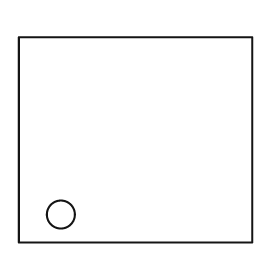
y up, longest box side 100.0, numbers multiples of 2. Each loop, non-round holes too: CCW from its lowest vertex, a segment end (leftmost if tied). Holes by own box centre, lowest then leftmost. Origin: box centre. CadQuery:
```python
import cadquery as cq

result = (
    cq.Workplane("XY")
    .moveTo(-50.0, -44.0)
    .lineTo(50.0, -44.0)
    .lineTo(50.0, 44.0)
    .lineTo(-50.0, 44.0)
    .close()
    .moveTo(-32.0, -32.0)
    .circle(6.0)
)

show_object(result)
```